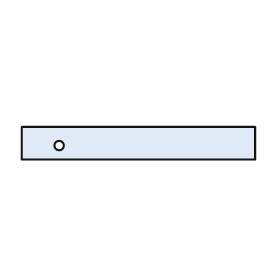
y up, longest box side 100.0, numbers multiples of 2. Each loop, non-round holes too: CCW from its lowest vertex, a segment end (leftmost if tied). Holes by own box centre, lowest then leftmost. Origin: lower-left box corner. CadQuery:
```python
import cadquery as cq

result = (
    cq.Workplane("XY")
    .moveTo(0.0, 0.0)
    .lineTo(100.0, 0.0)
    .lineTo(100.0, 14.0)
    .lineTo(0.0, 14.0)
    .close()
    .moveTo(16.0, 6.0)
    .circle(2.0)
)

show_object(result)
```